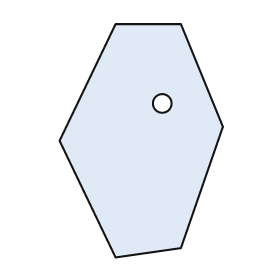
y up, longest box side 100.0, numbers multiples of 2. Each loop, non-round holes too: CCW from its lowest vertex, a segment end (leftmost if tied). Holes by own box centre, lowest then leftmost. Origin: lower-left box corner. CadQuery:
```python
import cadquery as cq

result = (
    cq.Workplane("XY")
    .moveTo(24.0, 0.0)
    .lineTo(52.0, 4.0)
    .lineTo(70.0, 56.0)
    .lineTo(52.0, 100.0)
    .lineTo(24.0, 100.0)
    .lineTo(0.0, 50.0)
    .close()
    .moveTo(44.0, 66.0)
    .circle(4.0)
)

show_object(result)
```